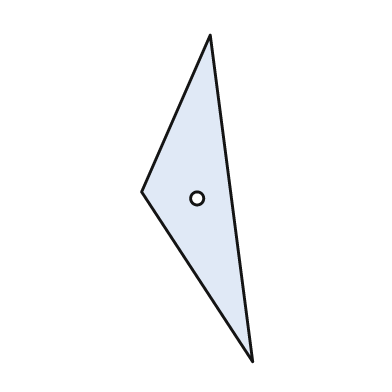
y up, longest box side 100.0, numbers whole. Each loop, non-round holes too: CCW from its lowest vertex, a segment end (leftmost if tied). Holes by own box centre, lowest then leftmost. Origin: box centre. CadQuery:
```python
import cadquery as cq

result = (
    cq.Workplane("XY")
    .moveTo(17.0, -50.0)
    .lineTo(4.0, 50.0)
    .lineTo(-17.0, 2.0)
    .close()
    .moveTo(0.0, 0.0)
    .circle(2.0)
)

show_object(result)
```